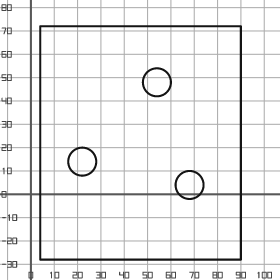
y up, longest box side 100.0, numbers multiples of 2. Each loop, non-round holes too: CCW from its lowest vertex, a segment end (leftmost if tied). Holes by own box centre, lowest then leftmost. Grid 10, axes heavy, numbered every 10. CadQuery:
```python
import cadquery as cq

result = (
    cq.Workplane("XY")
    .moveTo(4.0, -28.0)
    .lineTo(90.0, -28.0)
    .lineTo(90.0, 72.0)
    .lineTo(4.0, 72.0)
    .close()
    .moveTo(68.0, 4.0)
    .circle(6.0)
    .moveTo(22.0, 14.0)
    .circle(6.0)
    .moveTo(54.0, 48.0)
    .circle(6.0)
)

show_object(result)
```